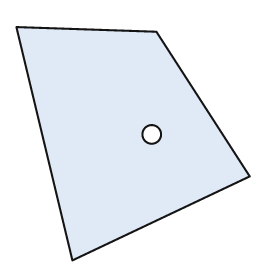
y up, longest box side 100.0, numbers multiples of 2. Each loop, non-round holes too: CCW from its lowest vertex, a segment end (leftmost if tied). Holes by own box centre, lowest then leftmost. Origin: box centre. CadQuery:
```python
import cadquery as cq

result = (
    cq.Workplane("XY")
    .moveTo(-26.0, -50.0)
    .lineTo(50.0, -14.0)
    .lineTo(10.0, 48.0)
    .lineTo(-50.0, 50.0)
    .close()
    .moveTo(8.0, 4.0)
    .circle(4.0)
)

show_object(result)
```